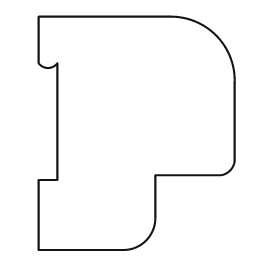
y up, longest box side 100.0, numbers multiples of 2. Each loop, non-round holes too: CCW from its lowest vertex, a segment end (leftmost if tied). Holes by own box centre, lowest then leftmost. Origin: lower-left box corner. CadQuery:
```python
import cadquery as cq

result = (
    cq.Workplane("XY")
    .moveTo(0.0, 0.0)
    .lineTo(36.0, 0.0)
    .threePointArc((46.0, 4.0), (50.0, 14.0))
    .lineTo(50.0, 32.0)
    .lineTo(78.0, 32.0)
    .threePointArc((82.0, 34.0), (84.0, 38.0))
    .lineTo(84.0, 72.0)
    .threePointArc((76.0, 92.0), (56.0, 100.0))
    .lineTo(0.0, 100.0)
    .lineTo(0.0, 80.0)
    .threePointArc((4.0, 78.0), (8.0, 80.0))
    .lineTo(8.0, 30.0)
    .lineTo(0.0, 30.0)
    .close()
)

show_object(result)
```